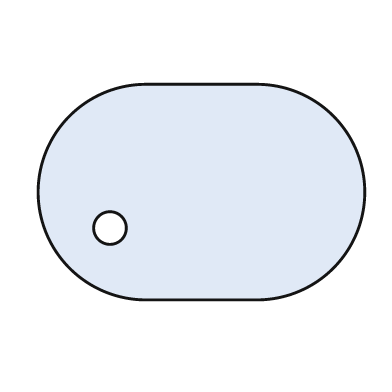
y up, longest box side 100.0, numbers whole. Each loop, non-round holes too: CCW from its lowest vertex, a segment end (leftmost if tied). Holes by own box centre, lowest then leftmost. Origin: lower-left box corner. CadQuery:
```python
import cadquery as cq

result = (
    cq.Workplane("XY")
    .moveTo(33.0, 0.0)
    .lineTo(67.0, 0.0)
    .threePointArc((100.0, 33.0), (67.0, 66.0))
    .lineTo(33.0, 66.0)
    .threePointArc((0.0, 33.0), (33.0, 0.0))
    .close()
    .moveTo(22.0, 22.0)
    .circle(5.0)
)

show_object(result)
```